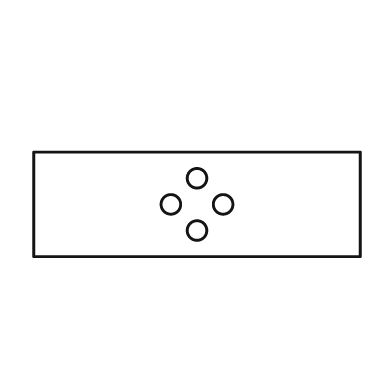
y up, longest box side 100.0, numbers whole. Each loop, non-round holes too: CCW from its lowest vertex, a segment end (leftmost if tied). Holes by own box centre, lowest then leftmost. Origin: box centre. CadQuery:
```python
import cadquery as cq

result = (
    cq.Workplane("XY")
    .moveTo(-50.0, -16.0)
    .lineTo(50.0, -16.0)
    .lineTo(50.0, 16.0)
    .lineTo(-50.0, 16.0)
    .close()
    .moveTo(0.0, -8.0)
    .circle(3.0)
    .moveTo(-8.0, 0.0)
    .circle(3.0)
    .moveTo(8.0, 0.0)
    .circle(3.0)
    .moveTo(0.0, 8.0)
    .circle(3.0)
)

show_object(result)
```